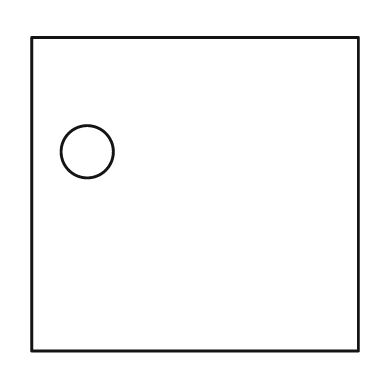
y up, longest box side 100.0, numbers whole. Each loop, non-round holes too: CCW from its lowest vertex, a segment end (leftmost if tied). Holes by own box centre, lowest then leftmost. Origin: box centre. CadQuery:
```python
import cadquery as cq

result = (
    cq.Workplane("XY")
    .moveTo(-50.0, -48.0)
    .lineTo(50.0, -48.0)
    .lineTo(50.0, 48.0)
    .lineTo(-50.0, 48.0)
    .close()
    .moveTo(-33.0, 13.0)
    .circle(8.0)
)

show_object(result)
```